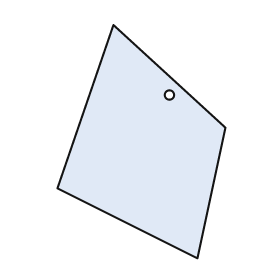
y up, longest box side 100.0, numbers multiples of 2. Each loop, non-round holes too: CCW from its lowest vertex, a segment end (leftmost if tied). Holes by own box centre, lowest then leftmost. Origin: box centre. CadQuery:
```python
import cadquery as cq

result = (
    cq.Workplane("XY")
    .moveTo(24.0, -50.0)
    .lineTo(36.0, 6.0)
    .lineTo(-12.0, 50.0)
    .lineTo(-36.0, -20.0)
    .close()
    .moveTo(12.0, 20.0)
    .circle(2.0)
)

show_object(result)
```